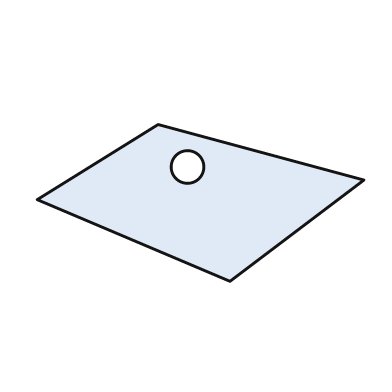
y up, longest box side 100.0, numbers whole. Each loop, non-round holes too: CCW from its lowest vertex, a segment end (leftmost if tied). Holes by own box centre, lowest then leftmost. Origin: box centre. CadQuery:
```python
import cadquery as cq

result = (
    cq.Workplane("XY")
    .moveTo(9.0, -24.0)
    .lineTo(50.0, 7.0)
    .lineTo(-13.0, 24.0)
    .lineTo(-50.0, 1.0)
    .close()
    .moveTo(-4.0, 11.0)
    .circle(5.0)
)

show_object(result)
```